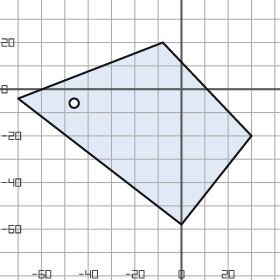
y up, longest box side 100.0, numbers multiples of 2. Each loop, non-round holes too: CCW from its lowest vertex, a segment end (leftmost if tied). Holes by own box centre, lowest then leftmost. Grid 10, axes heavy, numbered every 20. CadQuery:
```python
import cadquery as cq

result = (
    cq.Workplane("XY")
    .moveTo(0.0, -58.0)
    .lineTo(30.0, -20.0)
    .lineTo(-8.0, 20.0)
    .lineTo(-70.0, -4.0)
    .close()
    .moveTo(-46.0, -6.0)
    .circle(2.0)
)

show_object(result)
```